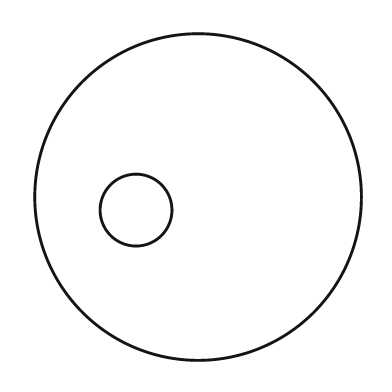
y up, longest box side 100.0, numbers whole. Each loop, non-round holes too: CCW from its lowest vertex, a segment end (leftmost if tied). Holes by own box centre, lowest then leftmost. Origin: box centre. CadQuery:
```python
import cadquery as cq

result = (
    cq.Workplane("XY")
    .moveTo(0.0, 0.0)
    .circle(50.0)
    .moveTo(-19.0, -4.0)
    .circle(11.0)
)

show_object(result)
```